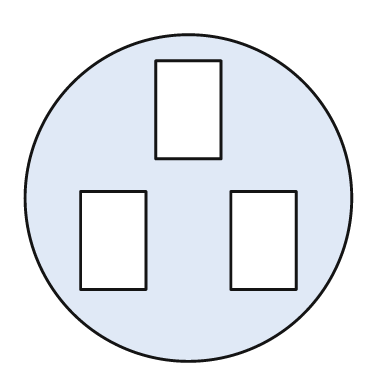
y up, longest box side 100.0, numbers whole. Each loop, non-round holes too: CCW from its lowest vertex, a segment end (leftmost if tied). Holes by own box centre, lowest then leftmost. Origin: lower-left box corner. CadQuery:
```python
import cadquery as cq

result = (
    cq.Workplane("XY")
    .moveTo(50.0, 50.0)
    .circle(50.0)
    .moveTo(17.0, 22.0)
    .lineTo(37.0, 22.0)
    .lineTo(37.0, 52.0)
    .lineTo(17.0, 52.0)
    .close()
    .moveTo(63.0, 22.0)
    .lineTo(83.0, 22.0)
    .lineTo(83.0, 52.0)
    .lineTo(63.0, 52.0)
    .close()
    .moveTo(40.0, 62.0)
    .lineTo(60.0, 62.0)
    .lineTo(60.0, 92.0)
    .lineTo(40.0, 92.0)
    .close()
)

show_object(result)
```